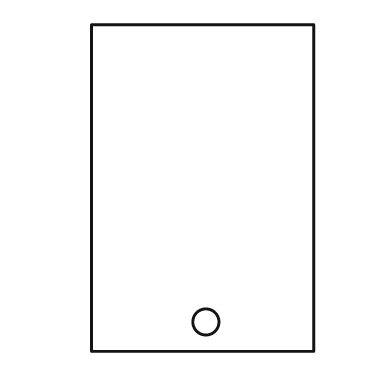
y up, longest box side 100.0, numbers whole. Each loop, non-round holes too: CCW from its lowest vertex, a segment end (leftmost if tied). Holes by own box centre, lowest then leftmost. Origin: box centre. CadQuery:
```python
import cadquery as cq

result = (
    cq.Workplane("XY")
    .moveTo(-34.0, -50.0)
    .lineTo(34.0, -50.0)
    .lineTo(34.0, 50.0)
    .lineTo(-34.0, 50.0)
    .close()
    .moveTo(1.0, -41.0)
    .circle(4.0)
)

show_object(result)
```